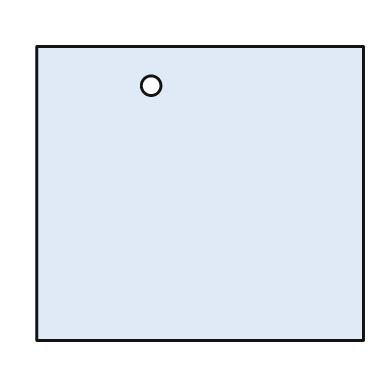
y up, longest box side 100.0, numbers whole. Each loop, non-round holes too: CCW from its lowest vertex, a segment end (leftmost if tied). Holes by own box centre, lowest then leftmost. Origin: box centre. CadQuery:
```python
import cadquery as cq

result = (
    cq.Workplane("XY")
    .moveTo(-50.0, -45.0)
    .lineTo(50.0, -45.0)
    .lineTo(50.0, 45.0)
    .lineTo(-50.0, 45.0)
    .close()
    .moveTo(-15.0, 33.0)
    .circle(3.0)
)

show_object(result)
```